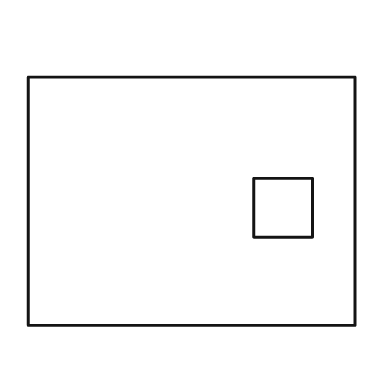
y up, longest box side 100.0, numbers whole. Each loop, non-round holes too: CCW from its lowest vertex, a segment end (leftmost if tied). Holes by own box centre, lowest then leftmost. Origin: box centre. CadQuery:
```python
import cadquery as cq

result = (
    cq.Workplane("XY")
    .moveTo(-50.0, -38.0)
    .lineTo(50.0, -38.0)
    .lineTo(50.0, 38.0)
    .lineTo(-50.0, 38.0)
    .close()
    .moveTo(19.0, -11.0)
    .lineTo(37.0, -11.0)
    .lineTo(37.0, 7.0)
    .lineTo(19.0, 7.0)
    .close()
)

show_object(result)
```